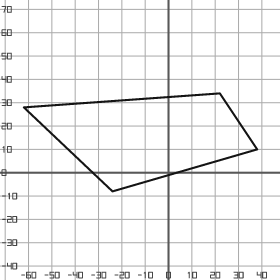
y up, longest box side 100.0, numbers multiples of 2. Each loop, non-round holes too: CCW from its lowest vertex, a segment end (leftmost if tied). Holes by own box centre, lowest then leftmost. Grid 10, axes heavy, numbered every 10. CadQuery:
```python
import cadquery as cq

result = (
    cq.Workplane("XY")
    .moveTo(-24.0, -8.0)
    .lineTo(38.0, 10.0)
    .lineTo(22.0, 34.0)
    .lineTo(-62.0, 28.0)
    .close()
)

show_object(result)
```